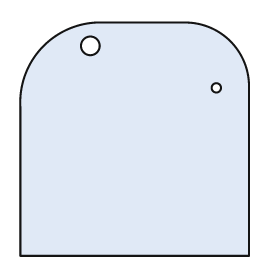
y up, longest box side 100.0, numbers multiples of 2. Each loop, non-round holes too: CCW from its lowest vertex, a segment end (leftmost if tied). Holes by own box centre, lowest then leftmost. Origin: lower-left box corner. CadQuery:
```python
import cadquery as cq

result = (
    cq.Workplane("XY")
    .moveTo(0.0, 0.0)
    .lineTo(98.0, 0.0)
    .lineTo(98.0, 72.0)
    .threePointArc((90.0, 92.0), (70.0, 100.0))
    .lineTo(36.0, 100.0)
    .threePointArc((10.0, 90.0), (0.0, 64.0))
    .close()
    .moveTo(84.0, 72.0)
    .circle(2.0)
    .moveTo(30.0, 90.0)
    .circle(4.0)
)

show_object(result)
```